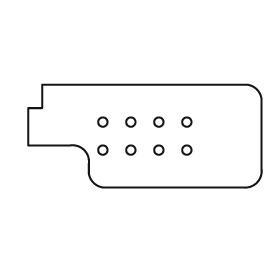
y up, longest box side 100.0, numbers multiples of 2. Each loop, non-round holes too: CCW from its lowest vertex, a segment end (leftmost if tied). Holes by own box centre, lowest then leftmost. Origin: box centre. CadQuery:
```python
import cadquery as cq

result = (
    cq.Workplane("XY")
    .moveTo(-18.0, -22.0)
    .lineTo(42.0, -22.0)
    .threePointArc((48.0, -20.0), (50.0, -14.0))
    .lineTo(50.0, 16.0)
    .threePointArc((48.0, 20.0), (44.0, 22.0))
    .lineTo(-44.0, 22.0)
    .lineTo(-44.0, 12.0)
    .lineTo(-50.0, 12.0)
    .lineTo(-50.0, -4.0)
    .lineTo(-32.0, -4.0)
    .threePointArc((-26.0, -6.0), (-24.0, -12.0))
    .lineTo(-24.0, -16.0)
    .threePointArc((-22.0, -20.0), (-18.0, -22.0))
    .close()
    .moveTo(-18.0, -6.0)
    .circle(2.0)
    .moveTo(-6.0, -6.0)
    .circle(2.0)
    .moveTo(6.0, -6.0)
    .circle(2.0)
    .moveTo(18.0, -6.0)
    .circle(2.0)
    .moveTo(-18.0, 6.0)
    .circle(2.0)
    .moveTo(-6.0, 6.0)
    .circle(2.0)
    .moveTo(6.0, 6.0)
    .circle(2.0)
    .moveTo(18.0, 6.0)
    .circle(2.0)
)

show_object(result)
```